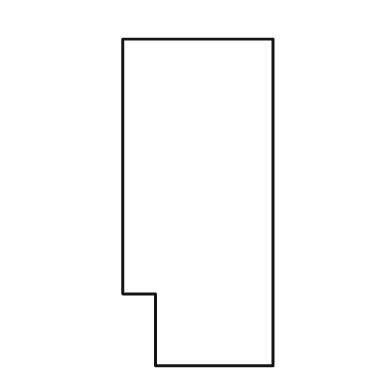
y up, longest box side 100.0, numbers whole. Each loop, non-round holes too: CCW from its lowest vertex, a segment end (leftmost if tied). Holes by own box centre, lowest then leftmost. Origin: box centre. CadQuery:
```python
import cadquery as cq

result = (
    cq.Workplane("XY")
    .moveTo(-13.0, -50.0)
    .lineTo(23.0, -50.0)
    .lineTo(23.0, 50.0)
    .lineTo(-23.0, 50.0)
    .lineTo(-23.0, -28.0)
    .lineTo(-13.0, -28.0)
    .close()
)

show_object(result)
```